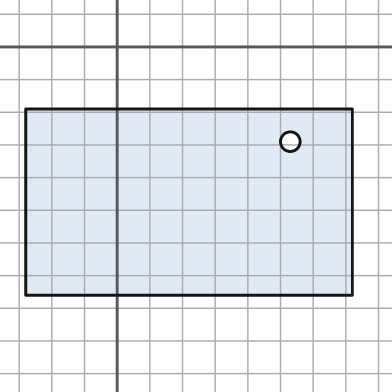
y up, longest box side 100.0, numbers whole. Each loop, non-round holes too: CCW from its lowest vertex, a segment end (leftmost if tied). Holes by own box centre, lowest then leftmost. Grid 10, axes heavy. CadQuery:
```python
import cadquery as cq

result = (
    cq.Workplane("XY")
    .moveTo(-28.0, -76.0)
    .lineTo(72.0, -76.0)
    .lineTo(72.0, -19.0)
    .lineTo(-28.0, -19.0)
    .close()
    .moveTo(53.0, -29.0)
    .circle(3.0)
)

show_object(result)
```